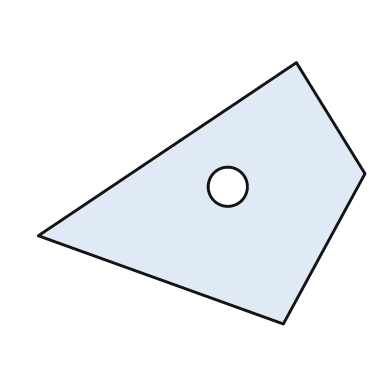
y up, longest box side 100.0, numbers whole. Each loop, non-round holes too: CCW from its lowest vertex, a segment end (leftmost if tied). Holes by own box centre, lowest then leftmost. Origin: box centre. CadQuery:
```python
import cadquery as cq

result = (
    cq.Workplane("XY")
    .moveTo(25.0, -40.0)
    .lineTo(50.0, 6.0)
    .lineTo(29.0, 40.0)
    .lineTo(-50.0, -13.0)
    .close()
    .moveTo(8.0, 2.0)
    .circle(6.0)
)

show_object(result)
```